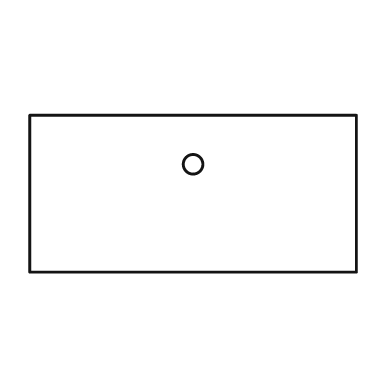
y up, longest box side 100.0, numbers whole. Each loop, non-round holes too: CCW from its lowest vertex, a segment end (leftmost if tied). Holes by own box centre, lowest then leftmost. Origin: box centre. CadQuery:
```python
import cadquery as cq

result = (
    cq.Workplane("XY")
    .moveTo(-50.0, -24.0)
    .lineTo(50.0, -24.0)
    .lineTo(50.0, 24.0)
    .lineTo(-50.0, 24.0)
    .close()
    .moveTo(0.0, 9.0)
    .circle(3.0)
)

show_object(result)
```